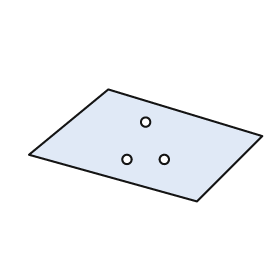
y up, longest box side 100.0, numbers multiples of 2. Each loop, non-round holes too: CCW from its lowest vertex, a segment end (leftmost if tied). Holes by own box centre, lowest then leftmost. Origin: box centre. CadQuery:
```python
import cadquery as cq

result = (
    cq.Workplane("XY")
    .moveTo(22.0, -24.0)
    .lineTo(50.0, 4.0)
    .lineTo(-16.0, 24.0)
    .lineTo(-50.0, -4.0)
    .close()
    .moveTo(-8.0, -6.0)
    .circle(2.0)
    .moveTo(8.0, -6.0)
    .circle(2.0)
    .moveTo(0.0, 10.0)
    .circle(2.0)
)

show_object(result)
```